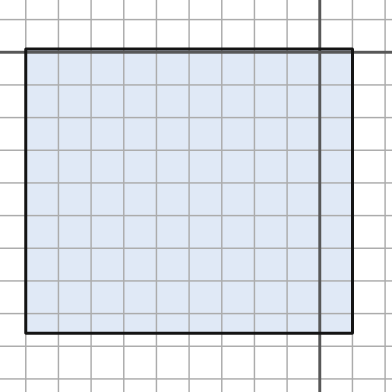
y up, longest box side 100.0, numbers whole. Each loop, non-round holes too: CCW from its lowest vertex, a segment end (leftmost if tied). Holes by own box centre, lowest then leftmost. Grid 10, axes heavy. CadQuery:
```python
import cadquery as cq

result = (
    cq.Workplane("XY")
    .moveTo(-90.0, -86.0)
    .lineTo(10.0, -86.0)
    .lineTo(10.0, 1.0)
    .lineTo(-90.0, 1.0)
    .close()
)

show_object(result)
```